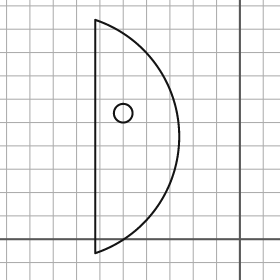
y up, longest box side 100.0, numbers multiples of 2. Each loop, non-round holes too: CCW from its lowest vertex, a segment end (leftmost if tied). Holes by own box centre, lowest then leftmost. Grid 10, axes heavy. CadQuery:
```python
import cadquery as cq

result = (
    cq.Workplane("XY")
    .moveTo(-62.0, -6.0)
    .threePointArc((-26.0, 44.0), (-62.0, 94.0))
    .close()
    .moveTo(-50.0, 54.0)
    .circle(4.0)
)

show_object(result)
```